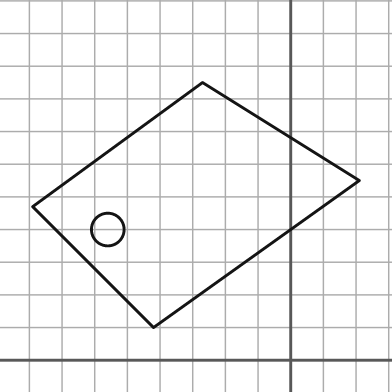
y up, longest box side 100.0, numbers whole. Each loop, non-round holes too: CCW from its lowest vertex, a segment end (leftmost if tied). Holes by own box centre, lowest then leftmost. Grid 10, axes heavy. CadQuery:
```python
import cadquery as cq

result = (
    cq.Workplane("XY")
    .moveTo(-42.0, 10.0)
    .lineTo(21.0, 55.0)
    .lineTo(-27.0, 85.0)
    .lineTo(-79.0, 47.0)
    .close()
    .moveTo(-56.0, 40.0)
    .circle(5.0)
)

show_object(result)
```